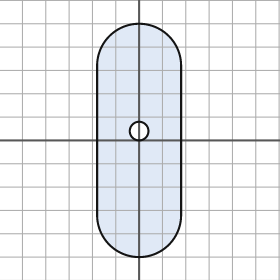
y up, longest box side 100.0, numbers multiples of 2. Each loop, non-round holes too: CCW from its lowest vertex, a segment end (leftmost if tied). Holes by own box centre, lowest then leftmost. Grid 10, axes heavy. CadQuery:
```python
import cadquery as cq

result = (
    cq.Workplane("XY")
    .moveTo(-18.0, -32.0)
    .threePointArc((0.0, -50.0), (18.0, -32.0))
    .lineTo(18.0, 32.0)
    .threePointArc((0.0, 50.0), (-18.0, 32.0))
    .close()
    .moveTo(0.0, 4.0)
    .circle(4.0)
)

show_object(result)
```